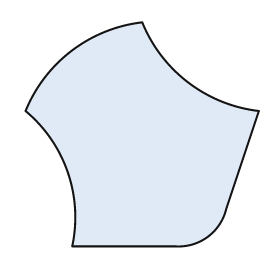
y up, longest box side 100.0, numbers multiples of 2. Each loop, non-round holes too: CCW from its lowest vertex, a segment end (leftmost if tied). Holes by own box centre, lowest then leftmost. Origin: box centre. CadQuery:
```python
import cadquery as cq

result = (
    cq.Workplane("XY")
    .moveTo(-30.0, -48.0)
    .lineTo(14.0, -48.0)
    .threePointArc((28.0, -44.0), (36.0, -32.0))
    .lineTo(50.0, 10.0)
    .threePointArc((20.0, 22.0), (0.0, 48.0))
    .threePointArc((-30.0, 36.0), (-50.0, 10.0))
    .threePointArc((-32.0, -16.0), (-30.0, -48.0))
    .close()
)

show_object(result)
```